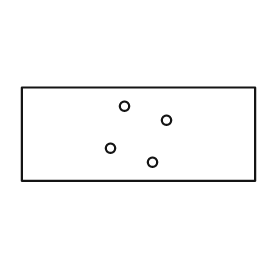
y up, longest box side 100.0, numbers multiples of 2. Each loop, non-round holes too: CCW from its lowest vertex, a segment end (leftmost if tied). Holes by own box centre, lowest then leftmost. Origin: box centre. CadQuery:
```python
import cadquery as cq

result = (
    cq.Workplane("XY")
    .moveTo(-50.0, -20.0)
    .lineTo(50.0, -20.0)
    .lineTo(50.0, 20.0)
    .lineTo(-50.0, 20.0)
    .close()
    .moveTo(6.0, -12.0)
    .circle(2.0)
    .moveTo(-12.0, -6.0)
    .circle(2.0)
    .moveTo(12.0, 6.0)
    .circle(2.0)
    .moveTo(-6.0, 12.0)
    .circle(2.0)
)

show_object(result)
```